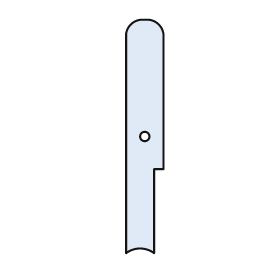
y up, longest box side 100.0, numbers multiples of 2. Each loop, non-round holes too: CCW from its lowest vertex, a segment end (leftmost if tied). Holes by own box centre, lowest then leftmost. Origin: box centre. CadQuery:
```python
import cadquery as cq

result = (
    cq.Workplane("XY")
    .moveTo(-8.0, -50.0)
    .threePointArc((-2.0, -48.0), (4.0, -50.0))
    .lineTo(4.0, -14.0)
    .lineTo(8.0, -14.0)
    .lineTo(8.0, 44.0)
    .threePointArc((6.0, 48.0), (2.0, 50.0))
    .lineTo(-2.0, 50.0)
    .threePointArc((-6.0, 48.0), (-8.0, 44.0))
    .close()
    .moveTo(0.0, 0.0)
    .circle(2.0)
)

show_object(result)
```